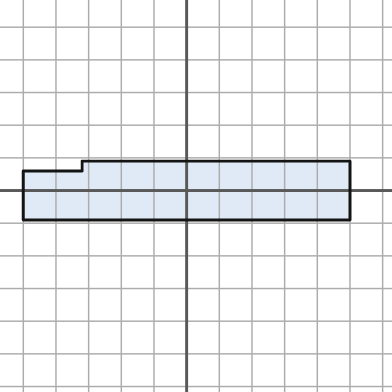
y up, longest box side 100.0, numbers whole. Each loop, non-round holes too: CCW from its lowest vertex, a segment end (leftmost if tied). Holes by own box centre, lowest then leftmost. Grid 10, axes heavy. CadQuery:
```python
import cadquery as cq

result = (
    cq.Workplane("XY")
    .moveTo(-50.0, -9.0)
    .lineTo(50.0, -9.0)
    .lineTo(50.0, 9.0)
    .lineTo(-32.0, 9.0)
    .lineTo(-32.0, 6.0)
    .lineTo(-50.0, 6.0)
    .close()
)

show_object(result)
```